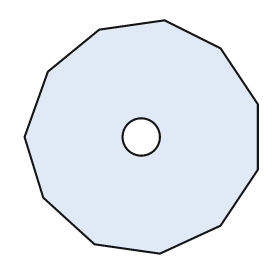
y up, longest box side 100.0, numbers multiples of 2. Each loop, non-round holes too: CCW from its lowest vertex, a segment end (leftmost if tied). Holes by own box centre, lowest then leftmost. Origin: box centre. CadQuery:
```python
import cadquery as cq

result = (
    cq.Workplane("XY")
    .moveTo(8.0, -50.0)
    .lineTo(34.0, -38.0)
    .lineTo(50.0, -14.0)
    .lineTo(50.0, 14.0)
    .lineTo(34.0, 38.0)
    .lineTo(10.0, 50.0)
    .lineTo(-18.0, 46.0)
    .lineTo(-40.0, 28.0)
    .lineTo(-50.0, 0.0)
    .lineTo(-42.0, -26.0)
    .lineTo(-20.0, -46.0)
    .close()
    .moveTo(0.0, 0.0)
    .circle(8.0)
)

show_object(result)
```